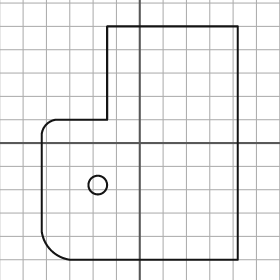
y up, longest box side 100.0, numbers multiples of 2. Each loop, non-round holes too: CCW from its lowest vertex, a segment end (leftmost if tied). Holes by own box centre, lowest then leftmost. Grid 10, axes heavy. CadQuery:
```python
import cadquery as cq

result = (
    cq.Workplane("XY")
    .moveTo(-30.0, -50.0)
    .lineTo(42.0, -50.0)
    .lineTo(42.0, 50.0)
    .lineTo(-14.0, 50.0)
    .lineTo(-14.0, 10.0)
    .lineTo(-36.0, 10.0)
    .threePointArc((-40.0, 8.0), (-42.0, 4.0))
    .lineTo(-42.0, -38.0)
    .threePointArc((-38.0, -46.0), (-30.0, -50.0))
    .close()
    .moveTo(-18.0, -18.0)
    .circle(4.0)
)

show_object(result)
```